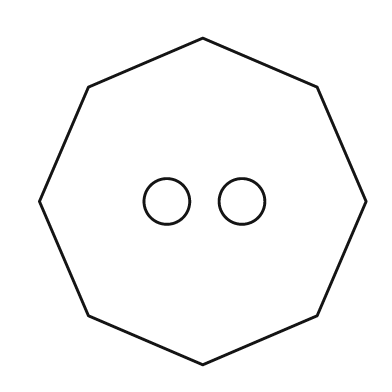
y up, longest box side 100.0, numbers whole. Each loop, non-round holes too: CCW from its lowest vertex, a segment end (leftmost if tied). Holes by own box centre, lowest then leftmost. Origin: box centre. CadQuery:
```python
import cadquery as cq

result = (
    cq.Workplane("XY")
    .moveTo(0.0, -50.0)
    .lineTo(35.0, -35.0)
    .lineTo(50.0, 0.0)
    .lineTo(35.0, 35.0)
    .lineTo(0.0, 50.0)
    .lineTo(-35.0, 35.0)
    .lineTo(-50.0, 0.0)
    .lineTo(-35.0, -35.0)
    .close()
    .moveTo(-11.0, 0.0)
    .circle(7.0)
    .moveTo(12.0, 0.0)
    .circle(7.0)
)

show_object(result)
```